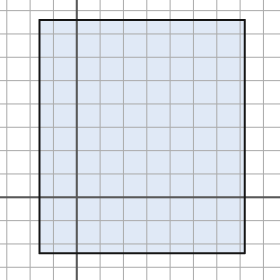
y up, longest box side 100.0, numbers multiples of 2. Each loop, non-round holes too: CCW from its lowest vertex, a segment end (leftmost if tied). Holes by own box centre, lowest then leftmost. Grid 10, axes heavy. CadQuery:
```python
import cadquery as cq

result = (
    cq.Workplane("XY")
    .moveTo(-16.0, -24.0)
    .lineTo(72.0, -24.0)
    .lineTo(72.0, 76.0)
    .lineTo(-16.0, 76.0)
    .close()
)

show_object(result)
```